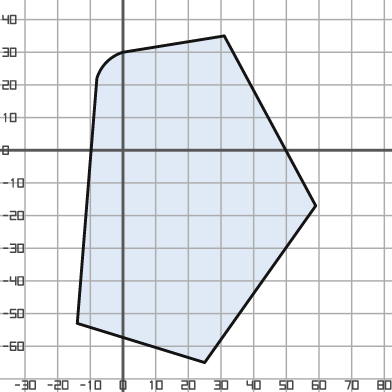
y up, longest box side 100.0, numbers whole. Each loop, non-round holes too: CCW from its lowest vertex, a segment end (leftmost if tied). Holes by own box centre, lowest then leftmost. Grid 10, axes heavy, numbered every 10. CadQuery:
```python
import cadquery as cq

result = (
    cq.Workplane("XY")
    .moveTo(25.0, -65.0)
    .lineTo(59.0, -17.0)
    .lineTo(31.0, 35.0)
    .lineTo(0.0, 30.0)
    .threePointArc((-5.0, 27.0), (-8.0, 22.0))
    .lineTo(-14.0, -53.0)
    .close()
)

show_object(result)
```